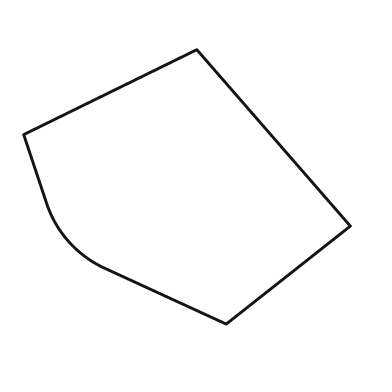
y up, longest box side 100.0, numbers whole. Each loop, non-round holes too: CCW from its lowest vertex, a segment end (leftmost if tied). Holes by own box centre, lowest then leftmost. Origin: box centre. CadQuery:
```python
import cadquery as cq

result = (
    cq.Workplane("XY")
    .moveTo(12.0, -42.0)
    .lineTo(50.0, -12.0)
    .lineTo(3.0, 42.0)
    .lineTo(-50.0, 16.0)
    .lineTo(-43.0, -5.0)
    .threePointArc((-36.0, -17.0), (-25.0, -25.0))
    .close()
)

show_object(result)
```